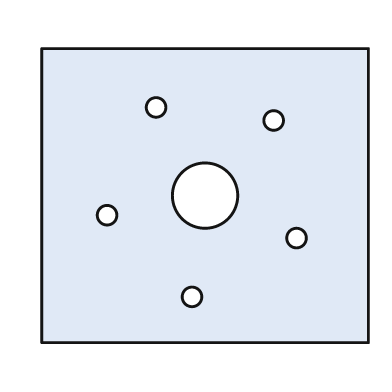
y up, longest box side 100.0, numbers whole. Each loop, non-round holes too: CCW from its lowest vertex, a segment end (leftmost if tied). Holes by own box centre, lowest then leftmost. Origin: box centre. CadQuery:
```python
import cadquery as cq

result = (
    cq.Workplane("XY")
    .moveTo(-50.0, -45.0)
    .lineTo(50.0, -45.0)
    .lineTo(50.0, 45.0)
    .lineTo(-50.0, 45.0)
    .close()
    .moveTo(-4.0, -31.0)
    .circle(3.0)
    .moveTo(28.0, -13.0)
    .circle(3.0)
    .moveTo(-30.0, -6.0)
    .circle(3.0)
    .moveTo(0.0, 0.0)
    .circle(10.0)
    .moveTo(21.0, 23.0)
    .circle(3.0)
    .moveTo(-15.0, 27.0)
    .circle(3.0)
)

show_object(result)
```